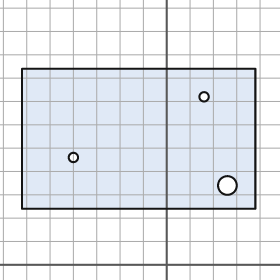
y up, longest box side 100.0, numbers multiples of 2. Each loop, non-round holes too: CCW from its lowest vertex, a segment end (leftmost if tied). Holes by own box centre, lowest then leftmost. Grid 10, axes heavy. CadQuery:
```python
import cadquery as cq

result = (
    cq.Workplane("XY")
    .moveTo(-62.0, 24.0)
    .lineTo(38.0, 24.0)
    .lineTo(38.0, 84.0)
    .lineTo(-62.0, 84.0)
    .close()
    .moveTo(26.0, 34.0)
    .circle(4.0)
    .moveTo(-40.0, 46.0)
    .circle(2.0)
    .moveTo(16.0, 72.0)
    .circle(2.0)
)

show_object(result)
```